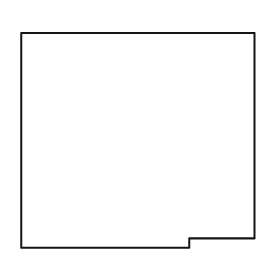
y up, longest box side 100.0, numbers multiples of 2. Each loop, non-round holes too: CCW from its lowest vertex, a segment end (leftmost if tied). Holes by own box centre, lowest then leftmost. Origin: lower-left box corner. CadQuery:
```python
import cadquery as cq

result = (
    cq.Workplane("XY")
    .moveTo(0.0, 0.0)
    .lineTo(72.0, 0.0)
    .lineTo(72.0, 4.0)
    .lineTo(100.0, 4.0)
    .lineTo(100.0, 92.0)
    .lineTo(0.0, 92.0)
    .close()
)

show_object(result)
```